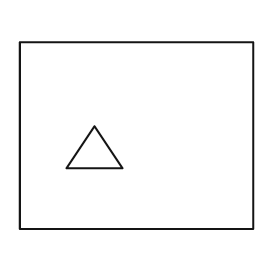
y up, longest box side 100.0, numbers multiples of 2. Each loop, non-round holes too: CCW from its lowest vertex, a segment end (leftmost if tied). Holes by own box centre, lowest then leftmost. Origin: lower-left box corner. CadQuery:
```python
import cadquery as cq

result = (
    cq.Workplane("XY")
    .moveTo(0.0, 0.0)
    .lineTo(100.0, 0.0)
    .lineTo(100.0, 80.0)
    .lineTo(0.0, 80.0)
    .close()
    .moveTo(20.0, 26.0)
    .lineTo(44.0, 26.0)
    .lineTo(32.0, 44.0)
    .close()
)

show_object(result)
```